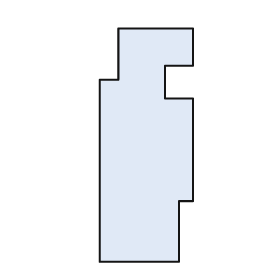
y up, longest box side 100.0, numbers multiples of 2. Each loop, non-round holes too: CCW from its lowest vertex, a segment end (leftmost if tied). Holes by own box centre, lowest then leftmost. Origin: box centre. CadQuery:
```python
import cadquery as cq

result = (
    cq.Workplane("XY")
    .moveTo(-20.0, -50.0)
    .lineTo(14.0, -50.0)
    .lineTo(14.0, -24.0)
    .lineTo(20.0, -24.0)
    .lineTo(20.0, 20.0)
    .lineTo(8.0, 20.0)
    .lineTo(8.0, 34.0)
    .lineTo(20.0, 34.0)
    .lineTo(20.0, 50.0)
    .lineTo(-12.0, 50.0)
    .lineTo(-12.0, 28.0)
    .lineTo(-20.0, 28.0)
    .close()
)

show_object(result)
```